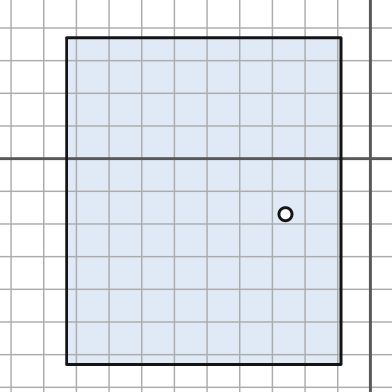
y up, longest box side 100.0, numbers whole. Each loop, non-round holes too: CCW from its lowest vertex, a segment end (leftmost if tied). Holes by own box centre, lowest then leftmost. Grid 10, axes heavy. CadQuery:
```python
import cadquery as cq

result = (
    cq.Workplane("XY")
    .moveTo(-93.0, -63.0)
    .lineTo(-9.0, -63.0)
    .lineTo(-9.0, 37.0)
    .lineTo(-93.0, 37.0)
    .close()
    .moveTo(-26.0, -17.0)
    .circle(2.0)
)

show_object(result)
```